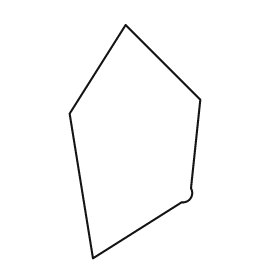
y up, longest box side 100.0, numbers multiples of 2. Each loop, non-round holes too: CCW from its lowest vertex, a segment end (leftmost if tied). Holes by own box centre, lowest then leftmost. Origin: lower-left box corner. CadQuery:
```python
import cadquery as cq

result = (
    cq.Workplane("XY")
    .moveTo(10.0, 0.0)
    .lineTo(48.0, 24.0)
    .threePointArc((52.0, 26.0), (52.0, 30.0))
    .lineTo(56.0, 68.0)
    .lineTo(24.0, 100.0)
    .lineTo(0.0, 62.0)
    .close()
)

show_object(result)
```